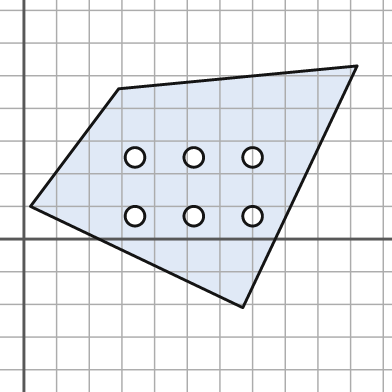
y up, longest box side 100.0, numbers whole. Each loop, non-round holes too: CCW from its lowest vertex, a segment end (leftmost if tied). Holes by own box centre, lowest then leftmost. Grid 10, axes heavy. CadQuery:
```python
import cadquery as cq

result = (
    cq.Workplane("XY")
    .moveTo(67.0, -21.0)
    .lineTo(102.0, 53.0)
    .lineTo(29.0, 46.0)
    .lineTo(2.0, 10.0)
    .close()
    .moveTo(34.0, 7.0)
    .circle(3.0)
    .moveTo(52.0, 7.0)
    .circle(3.0)
    .moveTo(70.0, 7.0)
    .circle(3.0)
    .moveTo(34.0, 25.0)
    .circle(3.0)
    .moveTo(52.0, 25.0)
    .circle(3.0)
    .moveTo(70.0, 25.0)
    .circle(3.0)
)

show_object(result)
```